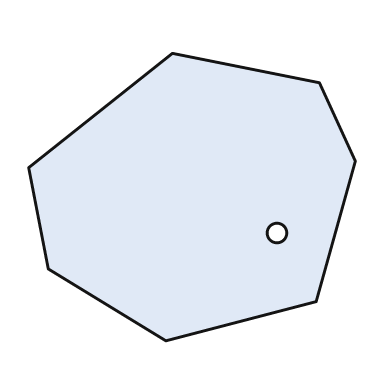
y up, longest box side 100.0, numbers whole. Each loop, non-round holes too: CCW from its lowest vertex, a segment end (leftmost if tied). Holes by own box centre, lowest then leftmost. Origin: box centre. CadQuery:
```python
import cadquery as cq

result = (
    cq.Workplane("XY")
    .moveTo(-8.0, -44.0)
    .lineTo(38.0, -32.0)
    .lineTo(50.0, 11.0)
    .lineTo(39.0, 35.0)
    .lineTo(-6.0, 44.0)
    .lineTo(-50.0, 9.0)
    .lineTo(-44.0, -22.0)
    .close()
    .moveTo(26.0, -11.0)
    .circle(3.0)
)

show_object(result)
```